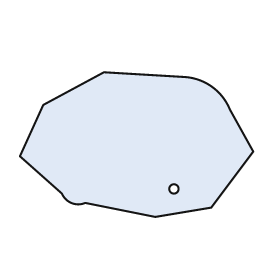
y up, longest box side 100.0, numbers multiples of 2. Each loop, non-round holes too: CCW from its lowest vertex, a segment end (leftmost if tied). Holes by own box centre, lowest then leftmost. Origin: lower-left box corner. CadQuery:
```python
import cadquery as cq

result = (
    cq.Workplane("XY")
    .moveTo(58.0, 0.0)
    .lineTo(82.0, 4.0)
    .lineTo(100.0, 28.0)
    .lineTo(90.0, 46.0)
    .threePointArc((82.0, 56.0), (70.0, 60.0))
    .lineTo(36.0, 62.0)
    .lineTo(10.0, 48.0)
    .lineTo(0.0, 26.0)
    .lineTo(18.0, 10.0)
    .threePointArc((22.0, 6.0), (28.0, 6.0))
    .close()
    .moveTo(66.0, 12.0)
    .circle(2.0)
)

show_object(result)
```